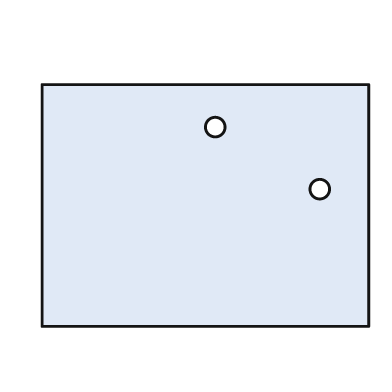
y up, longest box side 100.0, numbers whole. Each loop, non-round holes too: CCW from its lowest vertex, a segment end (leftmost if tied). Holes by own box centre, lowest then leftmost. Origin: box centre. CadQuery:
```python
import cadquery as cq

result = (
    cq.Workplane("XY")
    .moveTo(-50.0, -37.0)
    .lineTo(50.0, -37.0)
    .lineTo(50.0, 37.0)
    .lineTo(-50.0, 37.0)
    .close()
    .moveTo(35.0, 5.0)
    .circle(3.0)
    .moveTo(3.0, 24.0)
    .circle(3.0)
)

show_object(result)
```